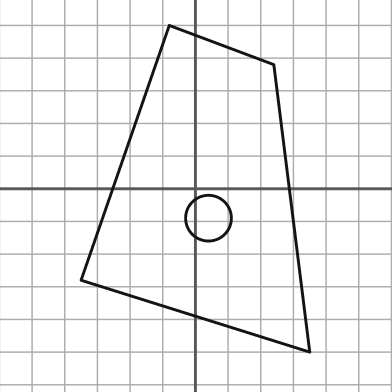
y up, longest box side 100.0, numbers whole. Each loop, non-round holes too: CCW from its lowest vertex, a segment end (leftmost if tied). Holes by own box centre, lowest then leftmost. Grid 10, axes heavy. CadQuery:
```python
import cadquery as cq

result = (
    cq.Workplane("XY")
    .moveTo(35.0, -50.0)
    .lineTo(24.0, 38.0)
    .lineTo(-8.0, 50.0)
    .lineTo(-35.0, -28.0)
    .close()
    .moveTo(4.0, -9.0)
    .circle(7.0)
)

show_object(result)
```